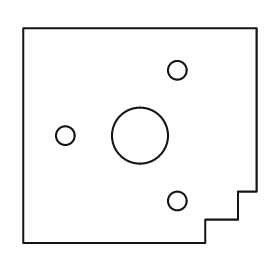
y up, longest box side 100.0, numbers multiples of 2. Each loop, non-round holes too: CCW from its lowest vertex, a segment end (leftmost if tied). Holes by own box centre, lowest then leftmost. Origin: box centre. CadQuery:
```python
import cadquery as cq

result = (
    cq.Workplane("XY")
    .moveTo(-50.0, -46.0)
    .lineTo(28.0, -46.0)
    .lineTo(28.0, -36.0)
    .lineTo(42.0, -36.0)
    .lineTo(42.0, -24.0)
    .lineTo(50.0, -24.0)
    .lineTo(50.0, 46.0)
    .lineTo(-50.0, 46.0)
    .close()
    .moveTo(16.0, -28.0)
    .circle(4.0)
    .moveTo(-32.0, 0.0)
    .circle(4.0)
    .moveTo(0.0, 0.0)
    .circle(12.0)
    .moveTo(16.0, 28.0)
    .circle(4.0)
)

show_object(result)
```